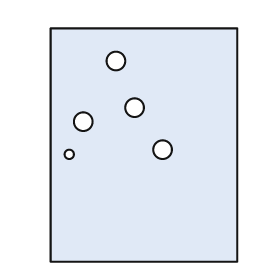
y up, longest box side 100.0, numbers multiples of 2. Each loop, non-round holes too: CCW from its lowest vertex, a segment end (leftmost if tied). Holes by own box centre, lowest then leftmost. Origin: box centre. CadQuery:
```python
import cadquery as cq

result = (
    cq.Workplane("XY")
    .moveTo(-40.0, -50.0)
    .lineTo(40.0, -50.0)
    .lineTo(40.0, 50.0)
    .lineTo(-40.0, 50.0)
    .close()
    .moveTo(-32.0, -4.0)
    .circle(2.0)
    .moveTo(8.0, -2.0)
    .circle(4.0)
    .moveTo(-26.0, 10.0)
    .circle(4.0)
    .moveTo(-4.0, 16.0)
    .circle(4.0)
    .moveTo(-12.0, 36.0)
    .circle(4.0)
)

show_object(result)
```